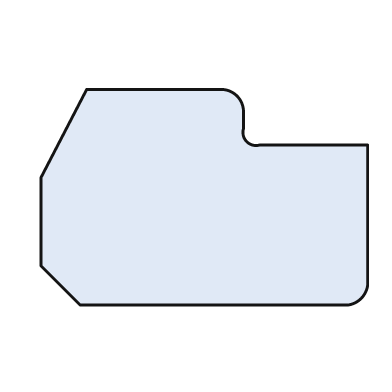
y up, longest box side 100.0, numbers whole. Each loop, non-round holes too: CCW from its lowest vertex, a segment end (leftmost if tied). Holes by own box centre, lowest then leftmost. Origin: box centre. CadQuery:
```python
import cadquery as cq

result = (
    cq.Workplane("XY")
    .moveTo(-38.0, -33.0)
    .lineTo(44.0, -33.0)
    .threePointArc((48.0, -31.0), (50.0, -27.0))
    .lineTo(50.0, 16.0)
    .lineTo(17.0, 16.0)
    .threePointArc((13.0, 17.0), (12.0, 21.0))
    .lineTo(12.0, 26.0)
    .threePointArc((10.0, 31.0), (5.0, 33.0))
    .lineTo(-36.0, 33.0)
    .lineTo(-50.0, 6.0)
    .lineTo(-50.0, -21.0)
    .close()
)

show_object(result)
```